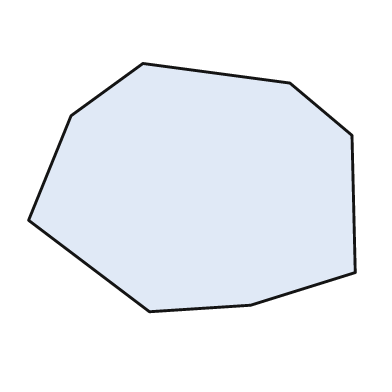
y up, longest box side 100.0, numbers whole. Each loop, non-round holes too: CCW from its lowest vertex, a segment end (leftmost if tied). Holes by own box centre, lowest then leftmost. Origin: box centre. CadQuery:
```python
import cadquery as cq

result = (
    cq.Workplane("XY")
    .moveTo(-13.0, -38.0)
    .lineTo(18.0, -36.0)
    .lineTo(50.0, -26.0)
    .lineTo(49.0, 16.0)
    .lineTo(30.0, 32.0)
    .lineTo(-15.0, 38.0)
    .lineTo(-37.0, 22.0)
    .lineTo(-50.0, -10.0)
    .close()
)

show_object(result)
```